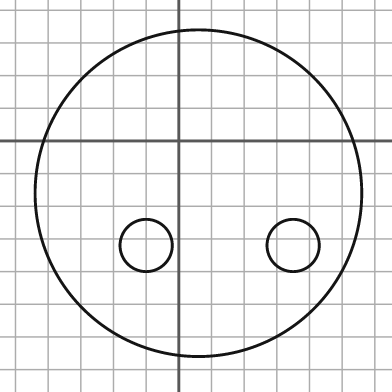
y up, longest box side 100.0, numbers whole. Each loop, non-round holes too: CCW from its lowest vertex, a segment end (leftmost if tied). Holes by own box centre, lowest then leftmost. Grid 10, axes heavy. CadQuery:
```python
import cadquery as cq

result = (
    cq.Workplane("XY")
    .moveTo(6.0, -16.0)
    .circle(50.0)
    .moveTo(-10.0, -32.0)
    .circle(8.0)
    .moveTo(35.0, -32.0)
    .circle(8.0)
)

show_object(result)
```